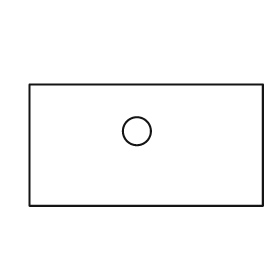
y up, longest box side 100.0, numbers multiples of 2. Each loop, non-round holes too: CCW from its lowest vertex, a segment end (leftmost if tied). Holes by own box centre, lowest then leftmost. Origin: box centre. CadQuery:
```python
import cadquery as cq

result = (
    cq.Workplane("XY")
    .moveTo(-50.0, -26.0)
    .lineTo(50.0, -26.0)
    .lineTo(50.0, 26.0)
    .lineTo(-50.0, 26.0)
    .close()
    .moveTo(-4.0, 6.0)
    .circle(6.0)
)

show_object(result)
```